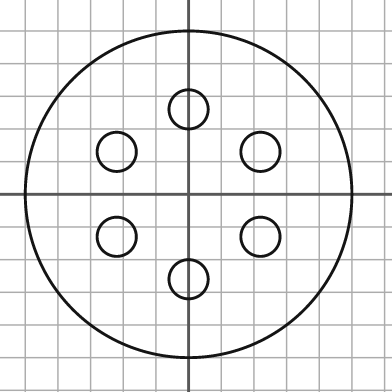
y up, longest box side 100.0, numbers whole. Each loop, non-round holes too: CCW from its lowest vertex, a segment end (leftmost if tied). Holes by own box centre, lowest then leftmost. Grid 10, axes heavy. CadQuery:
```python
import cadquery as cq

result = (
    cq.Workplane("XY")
    .moveTo(0.0, 0.0)
    .circle(50.0)
    .moveTo(0.0, -26.0)
    .circle(6.0)
    .moveTo(-22.0, -13.0)
    .circle(6.0)
    .moveTo(22.0, -13.0)
    .circle(6.0)
    .moveTo(-22.0, 13.0)
    .circle(6.0)
    .moveTo(22.0, 13.0)
    .circle(6.0)
    .moveTo(0.0, 26.0)
    .circle(6.0)
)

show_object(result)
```